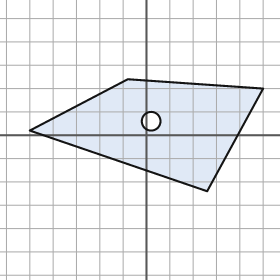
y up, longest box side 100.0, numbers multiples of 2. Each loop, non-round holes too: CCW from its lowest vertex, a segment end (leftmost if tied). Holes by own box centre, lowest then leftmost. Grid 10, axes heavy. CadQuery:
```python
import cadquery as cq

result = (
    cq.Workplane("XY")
    .moveTo(26.0, -24.0)
    .lineTo(50.0, 20.0)
    .lineTo(-8.0, 24.0)
    .lineTo(-50.0, 2.0)
    .close()
    .moveTo(2.0, 6.0)
    .circle(4.0)
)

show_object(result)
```